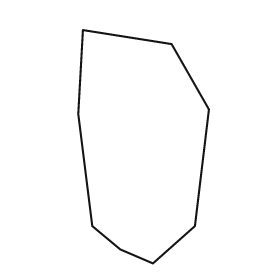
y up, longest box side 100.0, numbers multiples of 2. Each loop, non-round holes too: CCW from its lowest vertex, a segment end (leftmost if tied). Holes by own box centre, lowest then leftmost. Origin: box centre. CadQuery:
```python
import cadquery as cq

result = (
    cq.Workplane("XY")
    .moveTo(4.0, -50.0)
    .lineTo(22.0, -34.0)
    .lineTo(28.0, 16.0)
    .lineTo(12.0, 44.0)
    .lineTo(-26.0, 50.0)
    .lineTo(-28.0, 14.0)
    .lineTo(-22.0, -34.0)
    .lineTo(-10.0, -44.0)
    .close()
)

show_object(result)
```